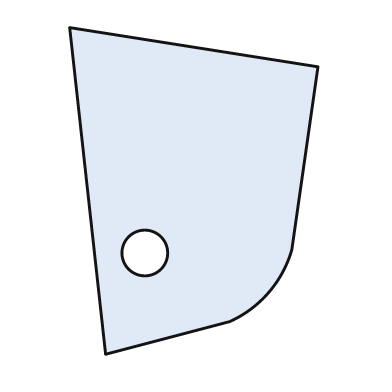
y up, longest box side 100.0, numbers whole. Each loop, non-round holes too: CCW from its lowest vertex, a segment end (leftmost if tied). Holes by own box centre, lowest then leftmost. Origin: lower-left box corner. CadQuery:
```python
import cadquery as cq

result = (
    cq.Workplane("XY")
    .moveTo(11.0, 0.0)
    .lineTo(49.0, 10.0)
    .threePointArc((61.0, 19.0), (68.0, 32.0))
    .lineTo(76.0, 88.0)
    .lineTo(0.0, 100.0)
    .close()
    .moveTo(23.0, 31.0)
    .circle(7.0)
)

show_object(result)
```